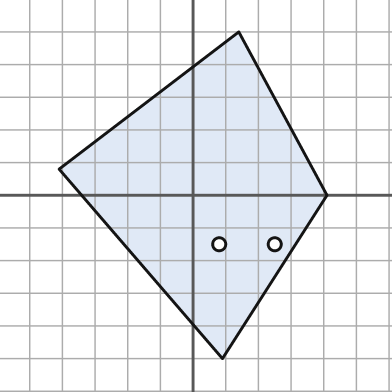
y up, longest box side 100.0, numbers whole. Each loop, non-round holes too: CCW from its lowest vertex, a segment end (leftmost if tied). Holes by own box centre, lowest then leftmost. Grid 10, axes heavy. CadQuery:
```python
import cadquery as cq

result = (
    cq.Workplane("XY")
    .moveTo(9.0, -50.0)
    .lineTo(41.0, 0.0)
    .lineTo(14.0, 50.0)
    .lineTo(-41.0, 8.0)
    .close()
    .moveTo(8.0, -15.0)
    .circle(2.0)
    .moveTo(25.0, -15.0)
    .circle(2.0)
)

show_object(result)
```